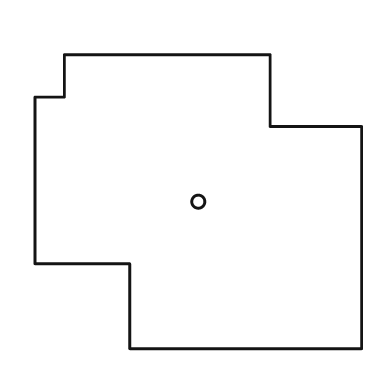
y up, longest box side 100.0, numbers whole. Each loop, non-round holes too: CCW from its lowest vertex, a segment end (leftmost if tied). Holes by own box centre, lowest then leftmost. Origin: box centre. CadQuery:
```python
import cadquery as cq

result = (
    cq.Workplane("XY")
    .moveTo(-21.0, -45.0)
    .lineTo(50.0, -45.0)
    .lineTo(50.0, 23.0)
    .lineTo(22.0, 23.0)
    .lineTo(22.0, 45.0)
    .lineTo(-41.0, 45.0)
    .lineTo(-41.0, 32.0)
    .lineTo(-50.0, 32.0)
    .lineTo(-50.0, -19.0)
    .lineTo(-21.0, -19.0)
    .close()
    .moveTo(0.0, 0.0)
    .circle(2.0)
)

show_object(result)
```